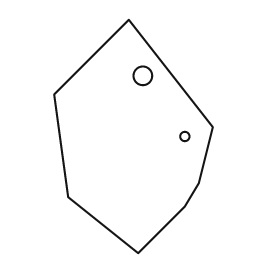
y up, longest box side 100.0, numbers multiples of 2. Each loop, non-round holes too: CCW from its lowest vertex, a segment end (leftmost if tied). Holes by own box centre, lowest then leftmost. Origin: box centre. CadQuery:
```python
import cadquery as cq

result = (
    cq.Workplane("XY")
    .moveTo(2.0, -50.0)
    .lineTo(22.0, -30.0)
    .lineTo(28.0, -20.0)
    .lineTo(34.0, 4.0)
    .lineTo(-2.0, 50.0)
    .lineTo(-34.0, 18.0)
    .lineTo(-28.0, -26.0)
    .close()
    .moveTo(22.0, 0.0)
    .circle(2.0)
    .moveTo(4.0, 26.0)
    .circle(4.0)
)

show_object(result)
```